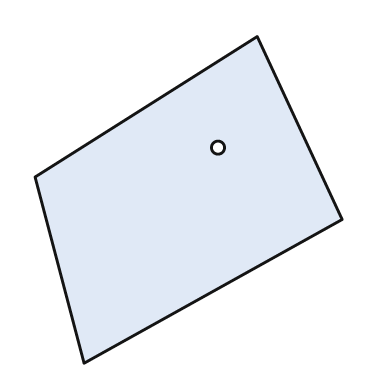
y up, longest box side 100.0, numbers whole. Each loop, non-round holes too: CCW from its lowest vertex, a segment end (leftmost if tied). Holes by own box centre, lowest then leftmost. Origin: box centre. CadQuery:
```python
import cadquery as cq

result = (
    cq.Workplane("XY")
    .moveTo(-32.0, -50.0)
    .lineTo(47.0, -6.0)
    .lineTo(21.0, 50.0)
    .lineTo(-47.0, 7.0)
    .close()
    .moveTo(9.0, 16.0)
    .circle(2.0)
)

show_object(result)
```